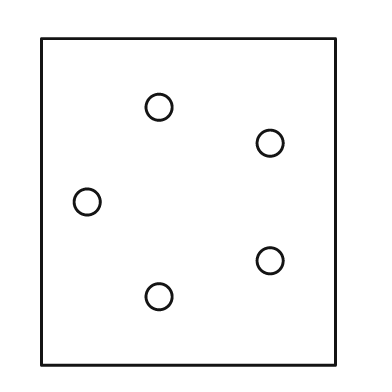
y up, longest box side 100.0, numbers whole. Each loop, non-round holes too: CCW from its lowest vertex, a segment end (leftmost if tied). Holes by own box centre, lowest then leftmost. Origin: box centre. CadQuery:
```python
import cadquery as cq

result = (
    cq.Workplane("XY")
    .moveTo(-45.0, -50.0)
    .lineTo(45.0, -50.0)
    .lineTo(45.0, 50.0)
    .lineTo(-45.0, 50.0)
    .close()
    .moveTo(-9.0, -29.0)
    .circle(4.0)
    .moveTo(25.0, -18.0)
    .circle(4.0)
    .moveTo(-31.0, 0.0)
    .circle(4.0)
    .moveTo(25.0, 18.0)
    .circle(4.0)
    .moveTo(-9.0, 29.0)
    .circle(4.0)
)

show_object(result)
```